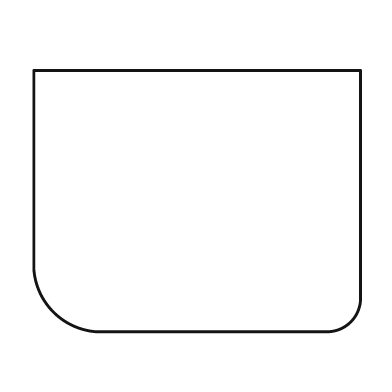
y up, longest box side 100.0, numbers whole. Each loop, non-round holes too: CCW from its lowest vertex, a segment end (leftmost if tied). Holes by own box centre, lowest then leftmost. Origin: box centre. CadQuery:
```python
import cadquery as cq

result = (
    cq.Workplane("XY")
    .moveTo(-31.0, -40.0)
    .lineTo(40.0, -40.0)
    .threePointArc((47.0, -37.0), (50.0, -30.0))
    .lineTo(50.0, 40.0)
    .lineTo(-50.0, 40.0)
    .lineTo(-50.0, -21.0)
    .threePointArc((-44.0, -34.0), (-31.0, -40.0))
    .close()
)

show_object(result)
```